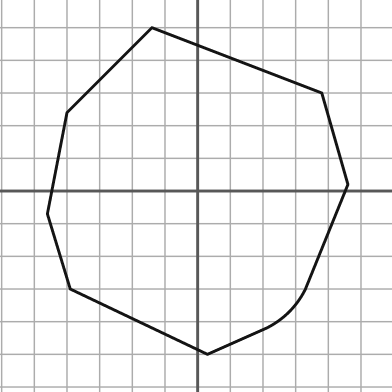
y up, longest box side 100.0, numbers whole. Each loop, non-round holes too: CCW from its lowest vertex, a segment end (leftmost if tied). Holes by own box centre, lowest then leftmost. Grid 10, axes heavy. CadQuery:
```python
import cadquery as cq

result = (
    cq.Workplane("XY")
    .moveTo(3.0, -50.0)
    .lineTo(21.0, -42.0)
    .threePointArc((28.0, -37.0), (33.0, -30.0))
    .lineTo(46.0, 2.0)
    .lineTo(38.0, 30.0)
    .lineTo(-14.0, 50.0)
    .lineTo(-40.0, 24.0)
    .lineTo(-46.0, -7.0)
    .lineTo(-39.0, -30.0)
    .close()
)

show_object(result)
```